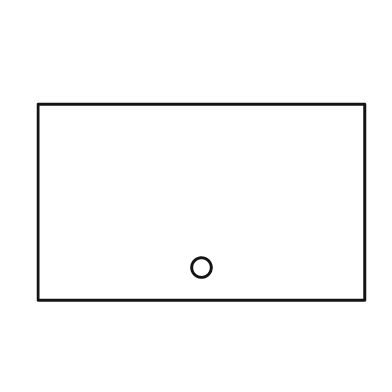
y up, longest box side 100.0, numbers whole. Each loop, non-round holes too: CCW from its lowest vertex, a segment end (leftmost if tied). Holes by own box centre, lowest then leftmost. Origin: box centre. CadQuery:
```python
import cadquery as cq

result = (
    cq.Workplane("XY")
    .moveTo(-50.0, -30.0)
    .lineTo(50.0, -30.0)
    .lineTo(50.0, 30.0)
    .lineTo(-50.0, 30.0)
    .close()
    .moveTo(0.0, -20.0)
    .circle(3.0)
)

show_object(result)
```